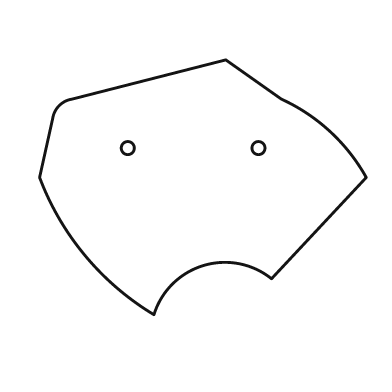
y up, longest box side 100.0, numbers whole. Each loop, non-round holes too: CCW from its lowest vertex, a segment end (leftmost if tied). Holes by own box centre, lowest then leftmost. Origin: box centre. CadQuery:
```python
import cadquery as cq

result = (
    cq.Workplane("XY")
    .moveTo(-15.0, -39.0)
    .threePointArc((0.0, -24.0), (21.0, -28.0))
    .lineTo(50.0, 3.0)
    .threePointArc((39.0, 17.0), (24.0, 27.0))
    .lineTo(7.0, 39.0)
    .lineTo(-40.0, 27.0)
    .threePointArc((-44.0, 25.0), (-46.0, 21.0))
    .lineTo(-50.0, 3.0)
    .threePointArc((-36.0, -21.0), (-15.0, -39.0))
    .close()
    .moveTo(-23.0, 12.0)
    .circle(2.0)
    .moveTo(17.0, 12.0)
    .circle(2.0)
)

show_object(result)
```